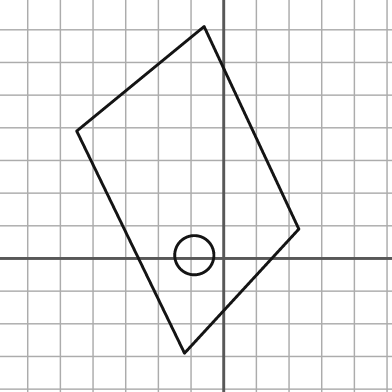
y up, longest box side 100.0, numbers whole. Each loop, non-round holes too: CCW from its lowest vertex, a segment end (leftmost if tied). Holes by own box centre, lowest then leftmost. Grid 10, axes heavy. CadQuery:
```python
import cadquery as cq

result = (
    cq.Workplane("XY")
    .moveTo(-12.0, -29.0)
    .lineTo(23.0, 9.0)
    .lineTo(-6.0, 71.0)
    .lineTo(-45.0, 39.0)
    .close()
    .moveTo(-9.0, 1.0)
    .circle(6.0)
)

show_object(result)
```